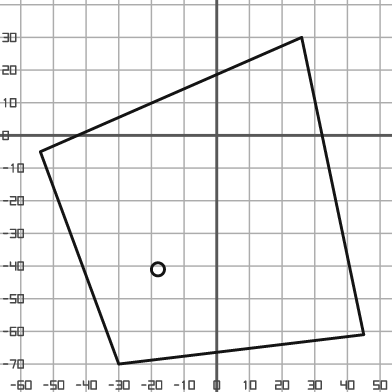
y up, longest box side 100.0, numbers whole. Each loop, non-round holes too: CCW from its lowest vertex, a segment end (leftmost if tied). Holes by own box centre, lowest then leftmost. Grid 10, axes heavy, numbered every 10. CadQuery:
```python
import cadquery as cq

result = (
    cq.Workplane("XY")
    .moveTo(-30.0, -70.0)
    .lineTo(45.0, -61.0)
    .lineTo(26.0, 30.0)
    .lineTo(-54.0, -5.0)
    .close()
    .moveTo(-18.0, -41.0)
    .circle(2.0)
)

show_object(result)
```